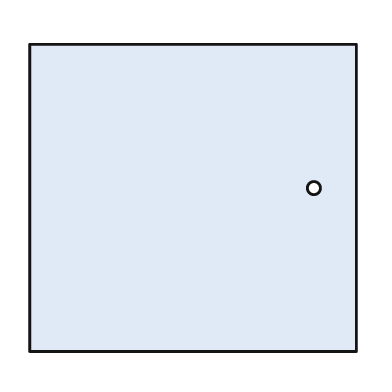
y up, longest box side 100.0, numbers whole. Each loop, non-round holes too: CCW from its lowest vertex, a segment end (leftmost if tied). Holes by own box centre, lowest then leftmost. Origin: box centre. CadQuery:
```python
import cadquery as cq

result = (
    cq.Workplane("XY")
    .moveTo(-50.0, -47.0)
    .lineTo(50.0, -47.0)
    .lineTo(50.0, 47.0)
    .lineTo(-50.0, 47.0)
    .close()
    .moveTo(37.0, 3.0)
    .circle(2.0)
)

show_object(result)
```